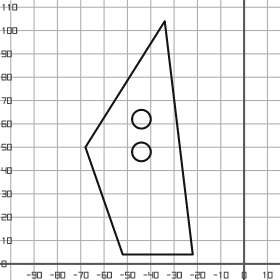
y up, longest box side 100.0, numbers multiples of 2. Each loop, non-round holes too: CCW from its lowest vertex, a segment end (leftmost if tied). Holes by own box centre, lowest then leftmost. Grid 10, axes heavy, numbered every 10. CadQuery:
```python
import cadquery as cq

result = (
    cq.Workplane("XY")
    .moveTo(-52.0, 4.0)
    .lineTo(-22.0, 4.0)
    .lineTo(-34.0, 104.0)
    .lineTo(-68.0, 50.0)
    .close()
    .moveTo(-44.0, 48.0)
    .circle(4.0)
    .moveTo(-44.0, 62.0)
    .circle(4.0)
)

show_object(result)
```